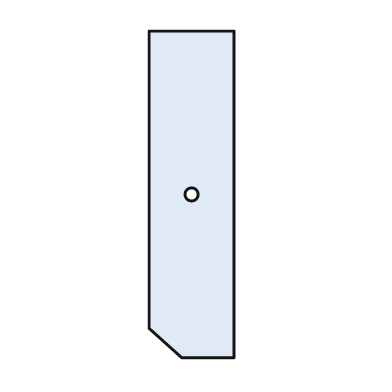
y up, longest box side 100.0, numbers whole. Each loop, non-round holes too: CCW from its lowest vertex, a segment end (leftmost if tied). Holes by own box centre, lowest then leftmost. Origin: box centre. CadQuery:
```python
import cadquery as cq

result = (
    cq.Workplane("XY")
    .moveTo(-3.0, -50.0)
    .lineTo(13.0, -50.0)
    .lineTo(13.0, 50.0)
    .lineTo(-13.0, 50.0)
    .lineTo(-13.0, -41.0)
    .close()
    .moveTo(0.0, 0.0)
    .circle(2.0)
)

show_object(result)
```